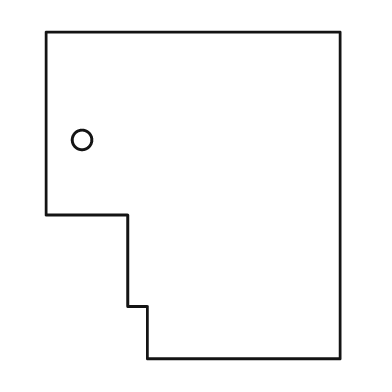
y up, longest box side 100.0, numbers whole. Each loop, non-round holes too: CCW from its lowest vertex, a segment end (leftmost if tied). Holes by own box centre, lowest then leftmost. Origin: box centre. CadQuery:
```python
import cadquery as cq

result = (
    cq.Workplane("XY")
    .moveTo(-14.0, -50.0)
    .lineTo(45.0, -50.0)
    .lineTo(45.0, 50.0)
    .lineTo(-45.0, 50.0)
    .lineTo(-45.0, -6.0)
    .lineTo(-20.0, -6.0)
    .lineTo(-20.0, -34.0)
    .lineTo(-14.0, -34.0)
    .close()
    .moveTo(-34.0, 17.0)
    .circle(3.0)
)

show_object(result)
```